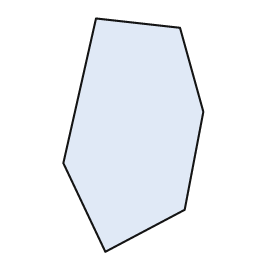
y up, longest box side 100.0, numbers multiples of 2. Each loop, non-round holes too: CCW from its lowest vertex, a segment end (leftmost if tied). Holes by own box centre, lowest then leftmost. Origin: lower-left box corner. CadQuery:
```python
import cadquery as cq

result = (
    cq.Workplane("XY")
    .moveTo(18.0, 0.0)
    .lineTo(52.0, 18.0)
    .lineTo(60.0, 60.0)
    .lineTo(50.0, 96.0)
    .lineTo(14.0, 100.0)
    .lineTo(0.0, 38.0)
    .close()
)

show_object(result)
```